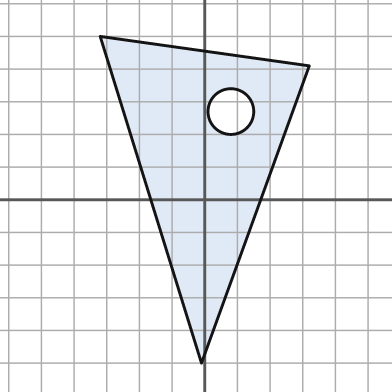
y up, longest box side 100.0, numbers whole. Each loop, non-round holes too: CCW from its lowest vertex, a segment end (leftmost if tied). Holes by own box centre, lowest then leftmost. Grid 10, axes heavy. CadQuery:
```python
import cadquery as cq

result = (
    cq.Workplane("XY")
    .moveTo(-1.0, -50.0)
    .lineTo(32.0, 41.0)
    .lineTo(-32.0, 50.0)
    .close()
    .moveTo(8.0, 27.0)
    .circle(7.0)
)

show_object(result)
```